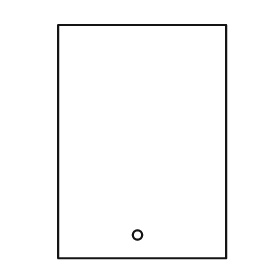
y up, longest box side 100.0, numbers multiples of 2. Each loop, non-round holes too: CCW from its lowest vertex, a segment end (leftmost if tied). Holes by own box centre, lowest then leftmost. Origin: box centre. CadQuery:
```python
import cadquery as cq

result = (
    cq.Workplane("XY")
    .moveTo(-36.0, -50.0)
    .lineTo(36.0, -50.0)
    .lineTo(36.0, 50.0)
    .lineTo(-36.0, 50.0)
    .close()
    .moveTo(-2.0, -40.0)
    .circle(2.0)
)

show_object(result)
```